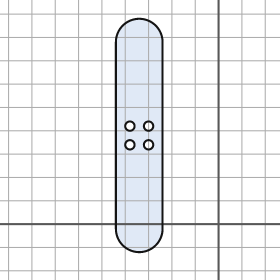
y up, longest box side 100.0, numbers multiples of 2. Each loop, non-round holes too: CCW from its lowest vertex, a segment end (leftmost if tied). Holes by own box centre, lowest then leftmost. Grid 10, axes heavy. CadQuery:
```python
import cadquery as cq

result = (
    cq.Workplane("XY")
    .moveTo(-44.0, -2.0)
    .threePointArc((-34.0, -12.0), (-24.0, -2.0))
    .lineTo(-24.0, 78.0)
    .threePointArc((-34.0, 88.0), (-44.0, 78.0))
    .close()
    .moveTo(-38.0, 34.0)
    .circle(2.0)
    .moveTo(-30.0, 34.0)
    .circle(2.0)
    .moveTo(-38.0, 42.0)
    .circle(2.0)
    .moveTo(-30.0, 42.0)
    .circle(2.0)
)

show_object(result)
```